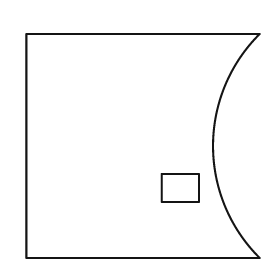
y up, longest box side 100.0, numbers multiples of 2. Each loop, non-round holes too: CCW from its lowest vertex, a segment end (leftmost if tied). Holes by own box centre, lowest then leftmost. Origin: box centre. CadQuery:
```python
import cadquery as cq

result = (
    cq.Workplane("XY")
    .moveTo(-50.0, -48.0)
    .lineTo(50.0, -48.0)
    .threePointArc((30.0, 0.0), (50.0, 48.0))
    .lineTo(-50.0, 48.0)
    .close()
    .moveTo(8.0, -24.0)
    .lineTo(24.0, -24.0)
    .lineTo(24.0, -12.0)
    .lineTo(8.0, -12.0)
    .close()
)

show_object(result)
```